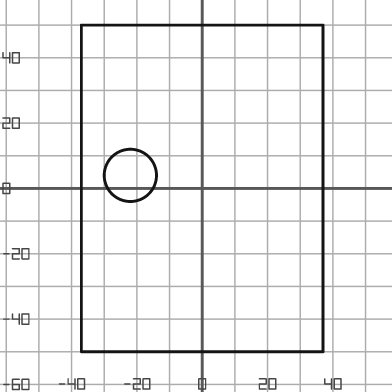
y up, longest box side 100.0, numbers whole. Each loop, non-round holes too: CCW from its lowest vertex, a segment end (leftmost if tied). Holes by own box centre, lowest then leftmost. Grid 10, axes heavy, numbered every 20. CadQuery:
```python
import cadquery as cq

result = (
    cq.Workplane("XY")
    .moveTo(-37.0, -50.0)
    .lineTo(37.0, -50.0)
    .lineTo(37.0, 50.0)
    .lineTo(-37.0, 50.0)
    .close()
    .moveTo(-22.0, 4.0)
    .circle(8.0)
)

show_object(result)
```